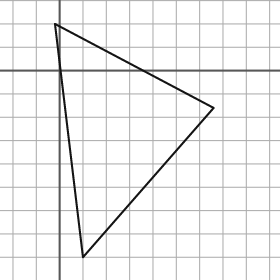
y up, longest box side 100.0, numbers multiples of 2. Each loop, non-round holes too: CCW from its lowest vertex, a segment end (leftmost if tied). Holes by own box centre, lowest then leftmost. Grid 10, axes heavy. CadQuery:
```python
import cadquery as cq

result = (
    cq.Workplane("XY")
    .moveTo(10.0, -80.0)
    .lineTo(66.0, -16.0)
    .lineTo(-2.0, 20.0)
    .close()
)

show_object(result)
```